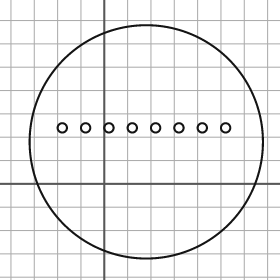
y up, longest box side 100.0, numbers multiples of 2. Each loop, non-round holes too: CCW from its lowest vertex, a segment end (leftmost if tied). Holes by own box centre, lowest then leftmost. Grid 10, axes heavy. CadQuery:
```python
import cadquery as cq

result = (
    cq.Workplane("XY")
    .moveTo(18.0, 18.0)
    .circle(50.0)
    .moveTo(-18.0, 24.0)
    .circle(2.0)
    .moveTo(-8.0, 24.0)
    .circle(2.0)
    .moveTo(2.0, 24.0)
    .circle(2.0)
    .moveTo(12.0, 24.0)
    .circle(2.0)
    .moveTo(22.0, 24.0)
    .circle(2.0)
    .moveTo(32.0, 24.0)
    .circle(2.0)
    .moveTo(42.0, 24.0)
    .circle(2.0)
    .moveTo(52.0, 24.0)
    .circle(2.0)
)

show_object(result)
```